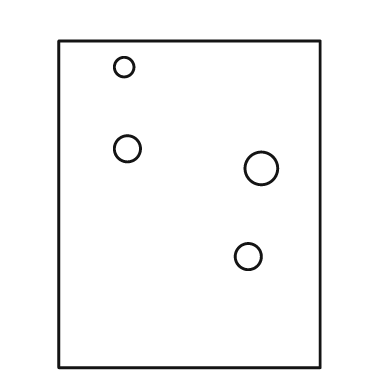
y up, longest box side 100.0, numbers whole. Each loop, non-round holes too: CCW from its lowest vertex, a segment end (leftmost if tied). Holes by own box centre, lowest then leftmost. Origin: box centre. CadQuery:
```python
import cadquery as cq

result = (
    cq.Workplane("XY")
    .moveTo(-40.0, -50.0)
    .lineTo(40.0, -50.0)
    .lineTo(40.0, 50.0)
    .lineTo(-40.0, 50.0)
    .close()
    .moveTo(18.0, -16.0)
    .circle(4.0)
    .moveTo(22.0, 11.0)
    .circle(5.0)
    .moveTo(-19.0, 17.0)
    .circle(4.0)
    .moveTo(-20.0, 42.0)
    .circle(3.0)
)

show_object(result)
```